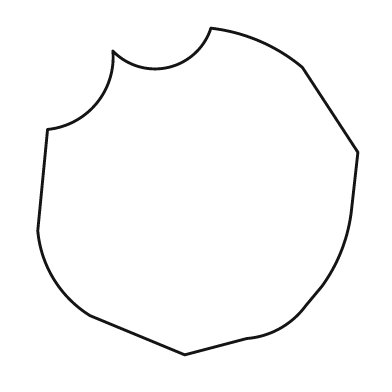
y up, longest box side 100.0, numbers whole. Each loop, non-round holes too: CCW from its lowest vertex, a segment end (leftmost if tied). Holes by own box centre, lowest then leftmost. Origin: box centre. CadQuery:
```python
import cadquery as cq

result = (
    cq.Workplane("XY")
    .moveTo(-4.0, -50.0)
    .lineTo(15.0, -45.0)
    .threePointArc((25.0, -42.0), (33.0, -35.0))
    .lineTo(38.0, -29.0)
    .threePointArc((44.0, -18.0), (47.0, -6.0))
    .lineTo(49.0, 12.0)
    .lineTo(32.0, 38.0)
    .threePointArc((19.0, 46.0), (4.0, 50.0))
    .threePointArc((-9.0, 38.0), (-26.0, 43.0))
    .threePointArc((-31.0, 27.0), (-46.0, 19.0))
    .lineTo(-49.0, -12.0)
    .threePointArc((-44.0, -27.0), (-33.0, -38.0))
    .close()
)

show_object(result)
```